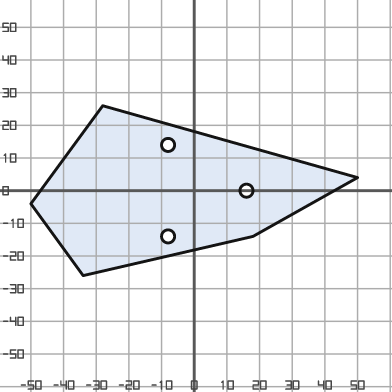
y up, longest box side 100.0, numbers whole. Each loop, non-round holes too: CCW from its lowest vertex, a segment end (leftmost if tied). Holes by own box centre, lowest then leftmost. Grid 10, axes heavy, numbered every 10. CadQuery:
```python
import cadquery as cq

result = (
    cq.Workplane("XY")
    .moveTo(-34.0, -26.0)
    .lineTo(18.0, -14.0)
    .lineTo(50.0, 4.0)
    .lineTo(-28.0, 26.0)
    .lineTo(-50.0, -4.0)
    .close()
    .moveTo(-8.0, -14.0)
    .circle(2.0)
    .moveTo(16.0, 0.0)
    .circle(2.0)
    .moveTo(-8.0, 14.0)
    .circle(2.0)
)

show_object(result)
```